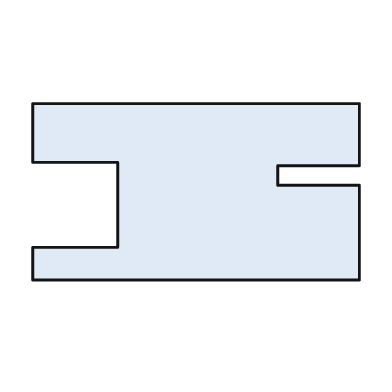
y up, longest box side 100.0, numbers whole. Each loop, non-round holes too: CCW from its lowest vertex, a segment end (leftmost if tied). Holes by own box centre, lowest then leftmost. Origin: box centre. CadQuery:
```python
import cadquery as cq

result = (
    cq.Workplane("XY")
    .moveTo(-50.0, -27.0)
    .lineTo(50.0, -27.0)
    .lineTo(50.0, 2.0)
    .lineTo(25.0, 2.0)
    .lineTo(25.0, 8.0)
    .lineTo(50.0, 8.0)
    .lineTo(50.0, 27.0)
    .lineTo(-50.0, 27.0)
    .lineTo(-50.0, 9.0)
    .lineTo(-24.0, 9.0)
    .lineTo(-24.0, -17.0)
    .lineTo(-50.0, -17.0)
    .close()
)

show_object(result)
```